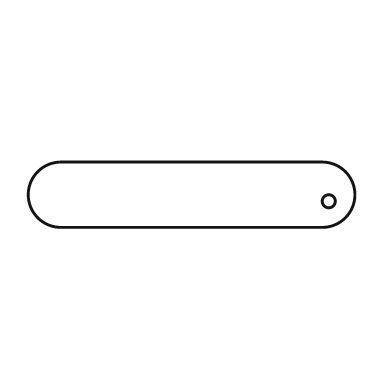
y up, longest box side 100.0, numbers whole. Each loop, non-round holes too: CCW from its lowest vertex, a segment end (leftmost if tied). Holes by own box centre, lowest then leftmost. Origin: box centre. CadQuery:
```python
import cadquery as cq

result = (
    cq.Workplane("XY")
    .moveTo(-40.0, -10.0)
    .lineTo(40.0, -10.0)
    .threePointArc((50.0, 0.0), (40.0, 10.0))
    .lineTo(-40.0, 10.0)
    .threePointArc((-50.0, 0.0), (-40.0, -10.0))
    .close()
    .moveTo(42.0, -2.0)
    .circle(2.0)
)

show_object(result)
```